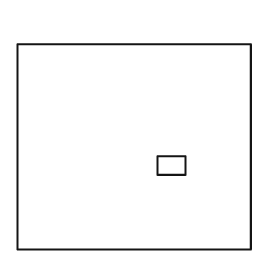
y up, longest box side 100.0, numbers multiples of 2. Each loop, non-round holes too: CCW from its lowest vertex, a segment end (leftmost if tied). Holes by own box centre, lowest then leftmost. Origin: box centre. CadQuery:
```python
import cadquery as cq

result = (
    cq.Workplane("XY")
    .moveTo(-50.0, -44.0)
    .lineTo(50.0, -44.0)
    .lineTo(50.0, 44.0)
    .lineTo(-50.0, 44.0)
    .close()
    .moveTo(10.0, -12.0)
    .lineTo(22.0, -12.0)
    .lineTo(22.0, -4.0)
    .lineTo(10.0, -4.0)
    .close()
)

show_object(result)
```